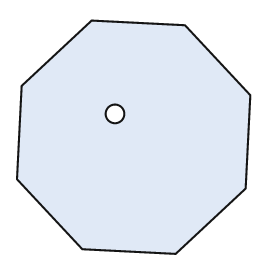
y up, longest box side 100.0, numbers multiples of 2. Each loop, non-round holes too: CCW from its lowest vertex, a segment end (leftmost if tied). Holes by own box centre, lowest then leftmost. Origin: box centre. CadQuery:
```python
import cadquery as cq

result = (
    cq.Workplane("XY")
    .moveTo(18.0, -50.0)
    .lineTo(48.0, -22.0)
    .lineTo(50.0, 18.0)
    .lineTo(22.0, 48.0)
    .lineTo(-18.0, 50.0)
    .lineTo(-48.0, 22.0)
    .lineTo(-50.0, -18.0)
    .lineTo(-22.0, -48.0)
    .close()
    .moveTo(-8.0, 10.0)
    .circle(4.0)
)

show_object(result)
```